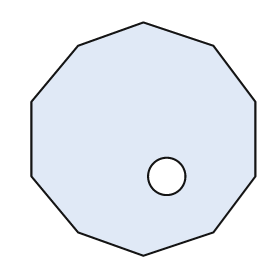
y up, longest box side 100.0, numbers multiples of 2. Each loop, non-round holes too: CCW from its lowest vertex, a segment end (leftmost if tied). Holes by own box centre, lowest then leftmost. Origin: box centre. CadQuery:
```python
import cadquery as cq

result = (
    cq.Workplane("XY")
    .moveTo(0.0, -50.0)
    .lineTo(30.0, -40.0)
    .lineTo(48.0, -16.0)
    .lineTo(48.0, 16.0)
    .lineTo(30.0, 40.0)
    .lineTo(0.0, 50.0)
    .lineTo(-28.0, 40.0)
    .lineTo(-48.0, 16.0)
    .lineTo(-48.0, -16.0)
    .lineTo(-28.0, -40.0)
    .close()
    .moveTo(10.0, -16.0)
    .circle(8.0)
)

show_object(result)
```